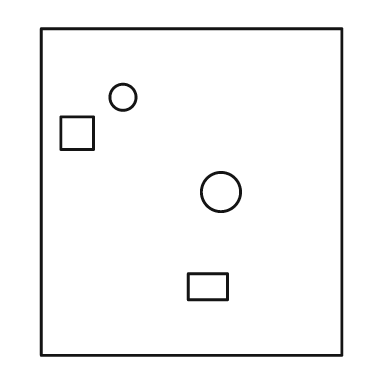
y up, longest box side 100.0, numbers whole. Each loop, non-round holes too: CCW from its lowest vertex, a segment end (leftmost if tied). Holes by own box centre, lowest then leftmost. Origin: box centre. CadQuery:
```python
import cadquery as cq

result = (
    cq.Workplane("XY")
    .moveTo(-46.0, -50.0)
    .lineTo(46.0, -50.0)
    .lineTo(46.0, 50.0)
    .lineTo(-46.0, 50.0)
    .close()
    .moveTo(-1.0, -33.0)
    .lineTo(11.0, -33.0)
    .lineTo(11.0, -25.0)
    .lineTo(-1.0, -25.0)
    .close()
    .moveTo(9.0, 0.0)
    .circle(6.0)
    .moveTo(-40.0, 13.0)
    .lineTo(-30.0, 13.0)
    .lineTo(-30.0, 23.0)
    .lineTo(-40.0, 23.0)
    .close()
    .moveTo(-21.0, 29.0)
    .circle(4.0)
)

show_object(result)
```